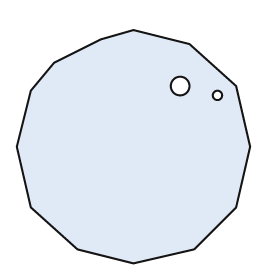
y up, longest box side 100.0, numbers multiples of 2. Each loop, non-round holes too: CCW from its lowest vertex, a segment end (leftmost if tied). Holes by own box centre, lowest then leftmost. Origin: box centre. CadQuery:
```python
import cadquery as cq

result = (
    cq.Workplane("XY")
    .moveTo(0.0, -50.0)
    .lineTo(26.0, -44.0)
    .lineTo(44.0, -26.0)
    .lineTo(50.0, 0.0)
    .lineTo(44.0, 26.0)
    .lineTo(24.0, 44.0)
    .lineTo(0.0, 50.0)
    .lineTo(-14.0, 46.0)
    .lineTo(-34.0, 36.0)
    .lineTo(-44.0, 24.0)
    .lineTo(-50.0, 0.0)
    .lineTo(-44.0, -26.0)
    .lineTo(-24.0, -44.0)
    .close()
    .moveTo(36.0, 22.0)
    .circle(2.0)
    .moveTo(20.0, 26.0)
    .circle(4.0)
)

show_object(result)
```